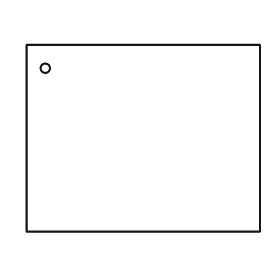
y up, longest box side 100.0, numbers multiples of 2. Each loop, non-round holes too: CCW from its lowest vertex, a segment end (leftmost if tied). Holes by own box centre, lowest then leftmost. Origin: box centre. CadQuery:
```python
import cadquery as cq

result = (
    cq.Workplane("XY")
    .moveTo(-50.0, -40.0)
    .lineTo(50.0, -40.0)
    .lineTo(50.0, 40.0)
    .lineTo(-50.0, 40.0)
    .close()
    .moveTo(-42.0, 30.0)
    .circle(2.0)
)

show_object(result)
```